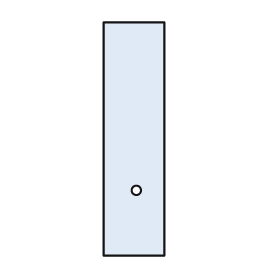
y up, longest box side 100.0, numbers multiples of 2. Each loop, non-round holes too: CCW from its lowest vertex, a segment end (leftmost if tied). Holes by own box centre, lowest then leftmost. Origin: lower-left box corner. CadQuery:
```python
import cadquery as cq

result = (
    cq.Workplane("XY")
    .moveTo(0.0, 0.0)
    .lineTo(26.0, 0.0)
    .lineTo(26.0, 100.0)
    .lineTo(0.0, 100.0)
    .close()
    .moveTo(14.0, 28.0)
    .circle(2.0)
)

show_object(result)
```